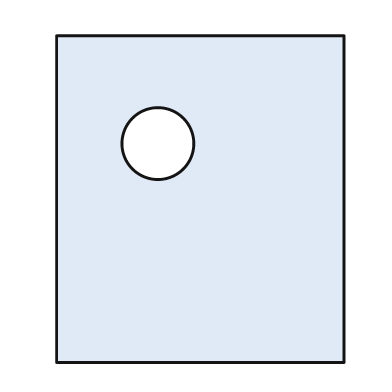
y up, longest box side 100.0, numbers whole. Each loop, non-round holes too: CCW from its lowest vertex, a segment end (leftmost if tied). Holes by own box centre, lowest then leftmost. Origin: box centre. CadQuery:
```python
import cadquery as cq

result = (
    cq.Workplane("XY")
    .moveTo(-44.0, -50.0)
    .lineTo(44.0, -50.0)
    .lineTo(44.0, 50.0)
    .lineTo(-44.0, 50.0)
    .close()
    .moveTo(-13.0, 17.0)
    .circle(11.0)
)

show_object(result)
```